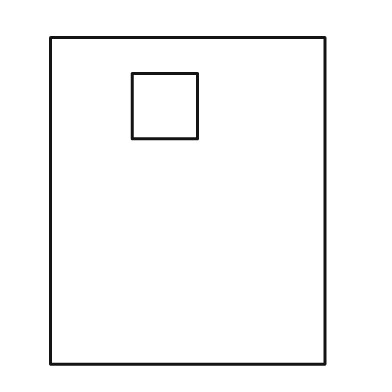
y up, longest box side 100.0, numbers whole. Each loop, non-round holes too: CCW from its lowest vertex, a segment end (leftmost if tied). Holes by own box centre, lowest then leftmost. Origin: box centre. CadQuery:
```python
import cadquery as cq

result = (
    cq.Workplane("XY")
    .moveTo(-42.0, -50.0)
    .lineTo(42.0, -50.0)
    .lineTo(42.0, 50.0)
    .lineTo(-42.0, 50.0)
    .close()
    .moveTo(-17.0, 19.0)
    .lineTo(3.0, 19.0)
    .lineTo(3.0, 39.0)
    .lineTo(-17.0, 39.0)
    .close()
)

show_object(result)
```